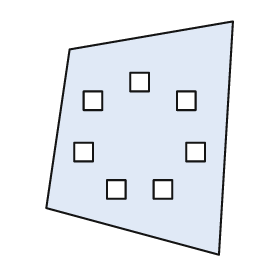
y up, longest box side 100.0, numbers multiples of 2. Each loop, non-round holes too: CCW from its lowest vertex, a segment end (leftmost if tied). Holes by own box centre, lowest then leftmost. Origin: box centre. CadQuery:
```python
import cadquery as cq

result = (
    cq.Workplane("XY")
    .moveTo(34.0, -50.0)
    .lineTo(40.0, 50.0)
    .lineTo(-30.0, 38.0)
    .lineTo(-40.0, -30.0)
    .close()
    .moveTo(-14.0, -26.0)
    .lineTo(-6.0, -26.0)
    .lineTo(-6.0, -18.0)
    .lineTo(-14.0, -18.0)
    .close()
    .moveTo(6.0, -26.0)
    .lineTo(14.0, -26.0)
    .lineTo(14.0, -18.0)
    .lineTo(6.0, -18.0)
    .close()
    .moveTo(-28.0, -10.0)
    .lineTo(-20.0, -10.0)
    .lineTo(-20.0, -2.0)
    .lineTo(-28.0, -2.0)
    .close()
    .moveTo(20.0, -10.0)
    .lineTo(28.0, -10.0)
    .lineTo(28.0, -2.0)
    .lineTo(20.0, -2.0)
    .close()
    .moveTo(-24.0, 12.0)
    .lineTo(-16.0, 12.0)
    .lineTo(-16.0, 20.0)
    .lineTo(-24.0, 20.0)
    .close()
    .moveTo(16.0, 12.0)
    .lineTo(24.0, 12.0)
    .lineTo(24.0, 20.0)
    .lineTo(16.0, 20.0)
    .close()
    .moveTo(-4.0, 20.0)
    .lineTo(4.0, 20.0)
    .lineTo(4.0, 28.0)
    .lineTo(-4.0, 28.0)
    .close()
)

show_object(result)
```